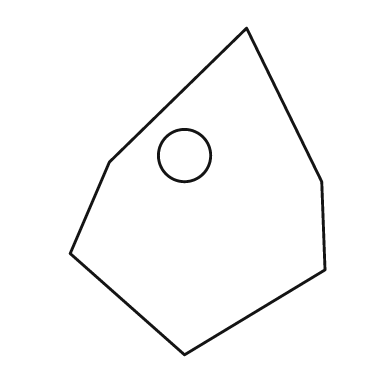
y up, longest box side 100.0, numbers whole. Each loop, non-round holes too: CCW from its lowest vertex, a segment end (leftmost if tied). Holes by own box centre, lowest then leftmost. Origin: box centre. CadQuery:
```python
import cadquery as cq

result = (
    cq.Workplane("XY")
    .moveTo(-4.0, -50.0)
    .lineTo(39.0, -24.0)
    .lineTo(38.0, 3.0)
    .lineTo(15.0, 50.0)
    .lineTo(-27.0, 9.0)
    .lineTo(-39.0, -19.0)
    .close()
    .moveTo(-4.0, 11.0)
    .circle(8.0)
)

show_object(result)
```